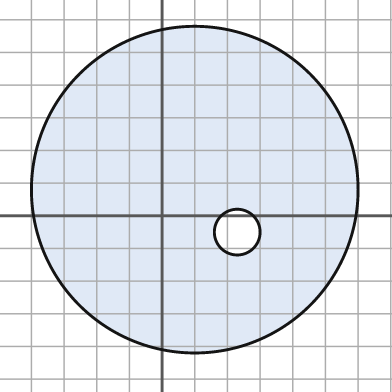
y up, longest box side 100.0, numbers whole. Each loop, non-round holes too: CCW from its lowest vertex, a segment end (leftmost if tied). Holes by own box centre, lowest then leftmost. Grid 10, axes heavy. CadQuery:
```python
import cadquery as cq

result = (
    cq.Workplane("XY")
    .moveTo(10.0, 8.0)
    .circle(50.0)
    .moveTo(23.0, -5.0)
    .circle(7.0)
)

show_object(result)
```